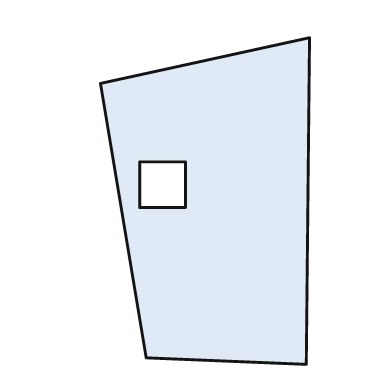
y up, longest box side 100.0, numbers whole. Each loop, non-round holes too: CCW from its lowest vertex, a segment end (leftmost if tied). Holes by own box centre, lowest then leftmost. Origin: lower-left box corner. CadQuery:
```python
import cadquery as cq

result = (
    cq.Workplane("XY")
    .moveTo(63.0, 0.0)
    .lineTo(64.0, 100.0)
    .lineTo(0.0, 86.0)
    .lineTo(14.0, 2.0)
    .close()
    .moveTo(12.0, 48.0)
    .lineTo(26.0, 48.0)
    .lineTo(26.0, 62.0)
    .lineTo(12.0, 62.0)
    .close()
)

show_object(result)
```